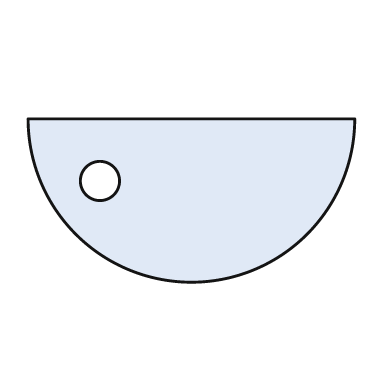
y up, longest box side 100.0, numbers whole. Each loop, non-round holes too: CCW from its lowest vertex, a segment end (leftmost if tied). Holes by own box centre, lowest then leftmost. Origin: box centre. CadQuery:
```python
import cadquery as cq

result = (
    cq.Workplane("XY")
    .moveTo(-50.0, 25.0)
    .threePointArc((0.0, -25.0), (50.0, 25.0))
    .close()
    .moveTo(-28.0, 6.0)
    .circle(6.0)
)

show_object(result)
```